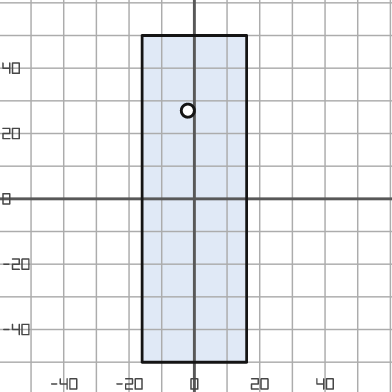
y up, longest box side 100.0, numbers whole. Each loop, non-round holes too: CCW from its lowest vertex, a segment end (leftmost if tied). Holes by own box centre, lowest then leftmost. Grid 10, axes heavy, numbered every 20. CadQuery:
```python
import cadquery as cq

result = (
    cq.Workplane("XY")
    .moveTo(-16.0, -50.0)
    .lineTo(16.0, -50.0)
    .lineTo(16.0, 50.0)
    .lineTo(-16.0, 50.0)
    .close()
    .moveTo(-2.0, 27.0)
    .circle(2.0)
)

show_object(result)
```